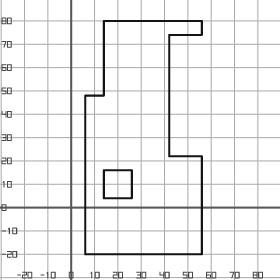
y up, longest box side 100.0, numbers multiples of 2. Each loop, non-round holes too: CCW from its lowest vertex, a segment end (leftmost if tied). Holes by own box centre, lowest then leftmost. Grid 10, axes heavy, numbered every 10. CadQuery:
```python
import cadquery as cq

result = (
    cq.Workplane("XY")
    .moveTo(6.0, -20.0)
    .lineTo(56.0, -20.0)
    .lineTo(56.0, 22.0)
    .lineTo(42.0, 22.0)
    .lineTo(42.0, 74.0)
    .lineTo(56.0, 74.0)
    .lineTo(56.0, 80.0)
    .lineTo(14.0, 80.0)
    .lineTo(14.0, 48.0)
    .lineTo(6.0, 48.0)
    .close()
    .moveTo(14.0, 4.0)
    .lineTo(26.0, 4.0)
    .lineTo(26.0, 16.0)
    .lineTo(14.0, 16.0)
    .close()
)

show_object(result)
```